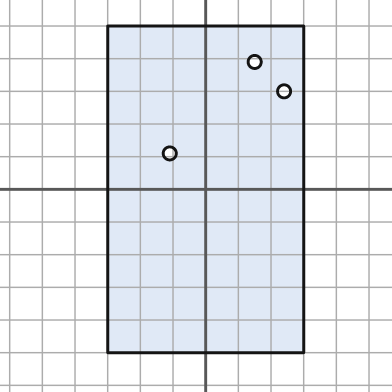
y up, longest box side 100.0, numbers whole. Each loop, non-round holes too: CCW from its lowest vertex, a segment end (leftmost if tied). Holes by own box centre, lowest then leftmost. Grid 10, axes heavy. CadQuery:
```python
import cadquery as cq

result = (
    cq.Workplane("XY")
    .moveTo(-30.0, -50.0)
    .lineTo(30.0, -50.0)
    .lineTo(30.0, 50.0)
    .lineTo(-30.0, 50.0)
    .close()
    .moveTo(-11.0, 11.0)
    .circle(2.0)
    .moveTo(24.0, 30.0)
    .circle(2.0)
    .moveTo(15.0, 39.0)
    .circle(2.0)
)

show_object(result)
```